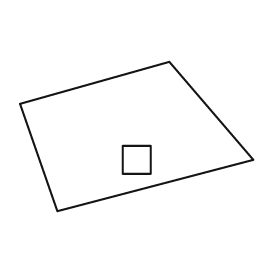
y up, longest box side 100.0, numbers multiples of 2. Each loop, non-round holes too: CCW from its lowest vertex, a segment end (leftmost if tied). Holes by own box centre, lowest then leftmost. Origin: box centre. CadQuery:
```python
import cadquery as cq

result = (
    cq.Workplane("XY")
    .moveTo(-34.0, -32.0)
    .lineTo(50.0, -10.0)
    .lineTo(14.0, 32.0)
    .lineTo(-50.0, 14.0)
    .close()
    .moveTo(-6.0, -16.0)
    .lineTo(6.0, -16.0)
    .lineTo(6.0, -4.0)
    .lineTo(-6.0, -4.0)
    .close()
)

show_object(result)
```